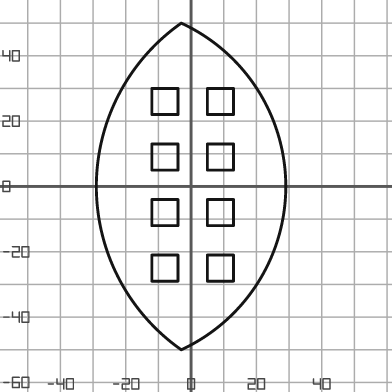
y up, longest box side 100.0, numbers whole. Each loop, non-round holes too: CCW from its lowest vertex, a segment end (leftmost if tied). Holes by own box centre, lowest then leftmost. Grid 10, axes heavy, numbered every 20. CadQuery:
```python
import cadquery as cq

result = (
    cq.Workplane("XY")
    .moveTo(-3.0, -50.0)
    .threePointArc((29.0, 0.0), (-3.0, 50.0))
    .threePointArc((-29.0, 0.0), (-3.0, -50.0))
    .close()
    .moveTo(-12.0, -29.0)
    .lineTo(-4.0, -29.0)
    .lineTo(-4.0, -21.0)
    .lineTo(-12.0, -21.0)
    .close()
    .moveTo(5.0, -29.0)
    .lineTo(13.0, -29.0)
    .lineTo(13.0, -21.0)
    .lineTo(5.0, -21.0)
    .close()
    .moveTo(-12.0, -12.0)
    .lineTo(-4.0, -12.0)
    .lineTo(-4.0, -4.0)
    .lineTo(-12.0, -4.0)
    .close()
    .moveTo(5.0, -12.0)
    .lineTo(13.0, -12.0)
    .lineTo(13.0, -4.0)
    .lineTo(5.0, -4.0)
    .close()
    .moveTo(-12.0, 5.0)
    .lineTo(-4.0, 5.0)
    .lineTo(-4.0, 13.0)
    .lineTo(-12.0, 13.0)
    .close()
    .moveTo(5.0, 5.0)
    .lineTo(13.0, 5.0)
    .lineTo(13.0, 13.0)
    .lineTo(5.0, 13.0)
    .close()
    .moveTo(-12.0, 22.0)
    .lineTo(-4.0, 22.0)
    .lineTo(-4.0, 30.0)
    .lineTo(-12.0, 30.0)
    .close()
    .moveTo(5.0, 22.0)
    .lineTo(13.0, 22.0)
    .lineTo(13.0, 30.0)
    .lineTo(5.0, 30.0)
    .close()
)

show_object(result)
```